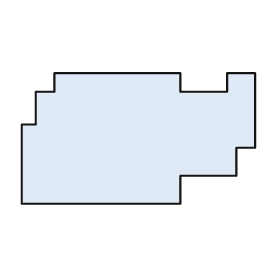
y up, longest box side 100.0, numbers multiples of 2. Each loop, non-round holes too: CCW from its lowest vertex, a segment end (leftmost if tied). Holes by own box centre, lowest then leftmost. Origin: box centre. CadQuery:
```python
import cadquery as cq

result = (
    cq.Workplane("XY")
    .moveTo(-50.0, -28.0)
    .lineTo(18.0, -28.0)
    .lineTo(18.0, -16.0)
    .lineTo(42.0, -16.0)
    .lineTo(42.0, -4.0)
    .lineTo(50.0, -4.0)
    .lineTo(50.0, 28.0)
    .lineTo(38.0, 28.0)
    .lineTo(38.0, 20.0)
    .lineTo(18.0, 20.0)
    .lineTo(18.0, 28.0)
    .lineTo(-36.0, 28.0)
    .lineTo(-36.0, 20.0)
    .lineTo(-44.0, 20.0)
    .lineTo(-44.0, 6.0)
    .lineTo(-50.0, 6.0)
    .close()
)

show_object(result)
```